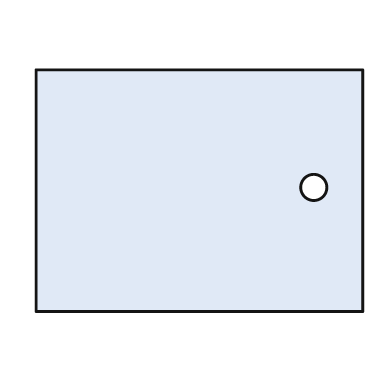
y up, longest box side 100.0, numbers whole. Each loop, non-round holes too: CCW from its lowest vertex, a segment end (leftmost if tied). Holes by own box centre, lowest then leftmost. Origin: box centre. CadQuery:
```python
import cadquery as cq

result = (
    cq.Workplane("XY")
    .moveTo(-50.0, -37.0)
    .lineTo(50.0, -37.0)
    .lineTo(50.0, 37.0)
    .lineTo(-50.0, 37.0)
    .close()
    .moveTo(35.0, 1.0)
    .circle(4.0)
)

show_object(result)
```